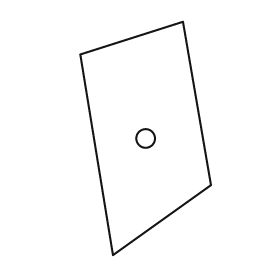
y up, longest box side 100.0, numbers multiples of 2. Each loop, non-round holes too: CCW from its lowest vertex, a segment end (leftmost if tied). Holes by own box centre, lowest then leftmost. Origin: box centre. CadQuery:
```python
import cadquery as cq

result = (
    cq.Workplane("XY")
    .moveTo(-14.0, -50.0)
    .lineTo(28.0, -20.0)
    .lineTo(16.0, 50.0)
    .lineTo(-28.0, 36.0)
    .close()
    .moveTo(0.0, 0.0)
    .circle(4.0)
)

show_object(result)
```